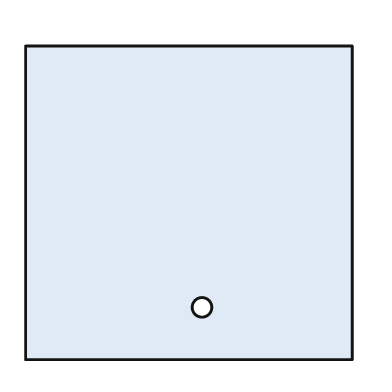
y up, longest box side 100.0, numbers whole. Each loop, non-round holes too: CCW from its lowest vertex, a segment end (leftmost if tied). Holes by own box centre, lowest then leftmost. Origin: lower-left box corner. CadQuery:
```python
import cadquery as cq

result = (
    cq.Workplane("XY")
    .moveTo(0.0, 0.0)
    .lineTo(100.0, 0.0)
    .lineTo(100.0, 96.0)
    .lineTo(0.0, 96.0)
    .close()
    .moveTo(54.0, 16.0)
    .circle(3.0)
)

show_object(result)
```